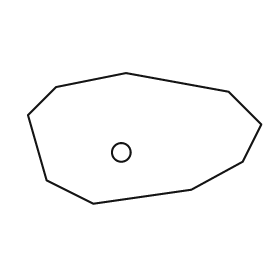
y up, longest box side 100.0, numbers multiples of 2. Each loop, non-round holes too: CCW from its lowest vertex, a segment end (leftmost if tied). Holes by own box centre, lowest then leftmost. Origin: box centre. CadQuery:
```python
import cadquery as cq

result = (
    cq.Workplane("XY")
    .moveTo(-22.0, -28.0)
    .lineTo(20.0, -22.0)
    .lineTo(42.0, -10.0)
    .lineTo(50.0, 6.0)
    .lineTo(36.0, 20.0)
    .lineTo(-8.0, 28.0)
    .lineTo(-38.0, 22.0)
    .lineTo(-50.0, 10.0)
    .lineTo(-42.0, -18.0)
    .close()
    .moveTo(-10.0, -6.0)
    .circle(4.0)
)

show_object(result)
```